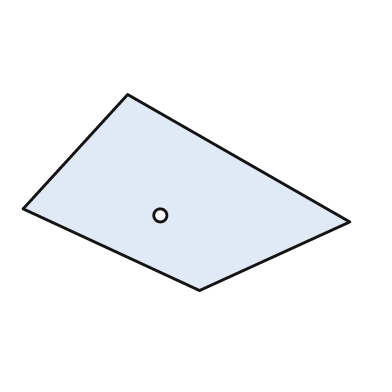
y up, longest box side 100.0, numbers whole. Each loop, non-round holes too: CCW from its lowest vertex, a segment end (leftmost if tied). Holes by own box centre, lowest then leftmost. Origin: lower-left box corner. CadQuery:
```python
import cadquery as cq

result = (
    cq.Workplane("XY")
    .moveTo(54.0, 0.0)
    .lineTo(100.0, 21.0)
    .lineTo(32.0, 60.0)
    .lineTo(0.0, 25.0)
    .close()
    .moveTo(42.0, 23.0)
    .circle(2.0)
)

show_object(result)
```